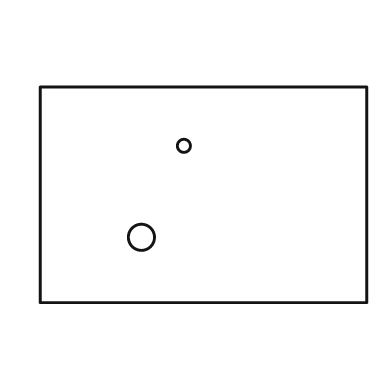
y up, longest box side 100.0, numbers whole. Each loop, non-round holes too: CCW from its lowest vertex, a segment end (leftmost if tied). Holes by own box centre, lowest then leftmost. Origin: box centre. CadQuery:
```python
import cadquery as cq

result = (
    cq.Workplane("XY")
    .moveTo(-50.0, -33.0)
    .lineTo(50.0, -33.0)
    .lineTo(50.0, 33.0)
    .lineTo(-50.0, 33.0)
    .close()
    .moveTo(-19.0, -13.0)
    .circle(4.0)
    .moveTo(-6.0, 15.0)
    .circle(2.0)
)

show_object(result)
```